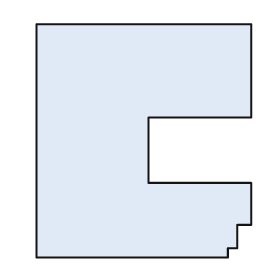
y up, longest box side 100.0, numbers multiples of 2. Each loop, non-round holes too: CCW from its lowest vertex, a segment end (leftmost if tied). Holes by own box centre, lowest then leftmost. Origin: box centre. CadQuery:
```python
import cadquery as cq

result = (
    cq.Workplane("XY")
    .moveTo(-46.0, -50.0)
    .lineTo(36.0, -50.0)
    .lineTo(36.0, -46.0)
    .lineTo(40.0, -46.0)
    .lineTo(40.0, -36.0)
    .lineTo(46.0, -36.0)
    .lineTo(46.0, -18.0)
    .lineTo(2.0, -18.0)
    .lineTo(2.0, 10.0)
    .lineTo(46.0, 10.0)
    .lineTo(46.0, 50.0)
    .lineTo(-46.0, 50.0)
    .close()
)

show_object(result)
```